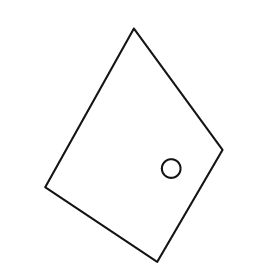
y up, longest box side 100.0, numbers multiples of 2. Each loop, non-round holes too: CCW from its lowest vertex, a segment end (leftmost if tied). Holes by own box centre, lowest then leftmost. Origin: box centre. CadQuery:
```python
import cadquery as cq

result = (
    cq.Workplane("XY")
    .moveTo(10.0, -50.0)
    .lineTo(38.0, -2.0)
    .lineTo(0.0, 50.0)
    .lineTo(-38.0, -18.0)
    .close()
    .moveTo(16.0, -10.0)
    .circle(4.0)
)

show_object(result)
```